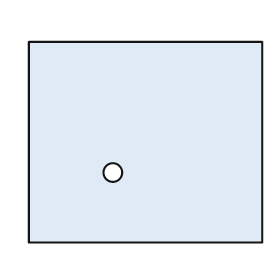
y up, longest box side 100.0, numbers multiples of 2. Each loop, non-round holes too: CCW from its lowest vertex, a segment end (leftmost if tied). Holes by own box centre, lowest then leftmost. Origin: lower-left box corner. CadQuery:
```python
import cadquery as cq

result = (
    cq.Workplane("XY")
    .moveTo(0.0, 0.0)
    .lineTo(100.0, 0.0)
    .lineTo(100.0, 86.0)
    .lineTo(0.0, 86.0)
    .close()
    .moveTo(36.0, 30.0)
    .circle(4.0)
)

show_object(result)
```